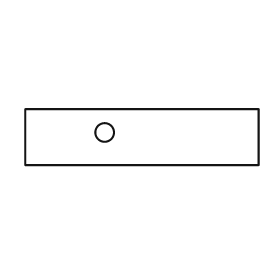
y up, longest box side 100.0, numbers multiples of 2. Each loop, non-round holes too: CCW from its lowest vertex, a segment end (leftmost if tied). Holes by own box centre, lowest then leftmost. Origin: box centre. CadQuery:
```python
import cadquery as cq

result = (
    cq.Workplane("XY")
    .moveTo(-50.0, -12.0)
    .lineTo(50.0, -12.0)
    .lineTo(50.0, 12.0)
    .lineTo(-50.0, 12.0)
    .close()
    .moveTo(-16.0, 2.0)
    .circle(4.0)
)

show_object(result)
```